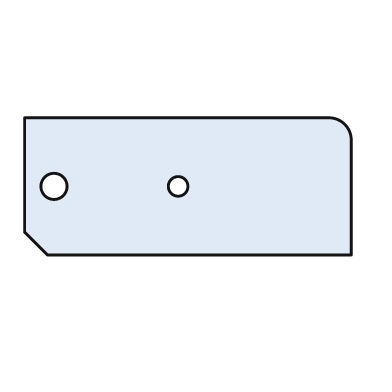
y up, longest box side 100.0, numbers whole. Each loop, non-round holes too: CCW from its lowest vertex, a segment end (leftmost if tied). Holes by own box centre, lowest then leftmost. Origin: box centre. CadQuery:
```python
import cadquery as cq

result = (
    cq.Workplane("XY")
    .moveTo(-43.0, -21.0)
    .lineTo(50.0, -21.0)
    .lineTo(50.0, 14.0)
    .threePointArc((48.0, 19.0), (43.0, 21.0))
    .lineTo(-50.0, 21.0)
    .lineTo(-50.0, -14.0)
    .close()
    .moveTo(-41.0, 0.0)
    .circle(4.0)
    .moveTo(-3.0, 0.0)
    .circle(3.0)
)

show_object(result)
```